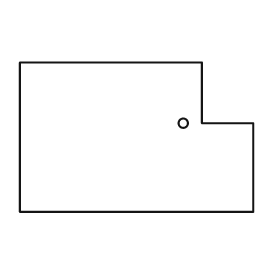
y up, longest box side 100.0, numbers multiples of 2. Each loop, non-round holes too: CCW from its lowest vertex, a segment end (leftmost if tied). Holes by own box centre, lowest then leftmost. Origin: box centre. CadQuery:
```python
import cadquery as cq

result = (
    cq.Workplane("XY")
    .moveTo(-50.0, -32.0)
    .lineTo(50.0, -32.0)
    .lineTo(50.0, 6.0)
    .lineTo(28.0, 6.0)
    .lineTo(28.0, 32.0)
    .lineTo(-50.0, 32.0)
    .close()
    .moveTo(20.0, 6.0)
    .circle(2.0)
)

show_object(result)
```